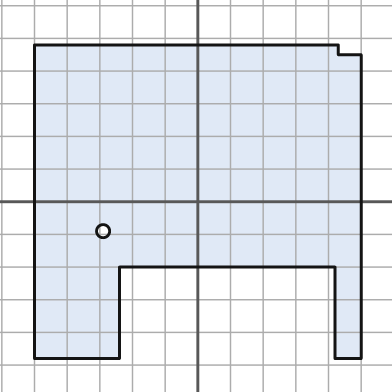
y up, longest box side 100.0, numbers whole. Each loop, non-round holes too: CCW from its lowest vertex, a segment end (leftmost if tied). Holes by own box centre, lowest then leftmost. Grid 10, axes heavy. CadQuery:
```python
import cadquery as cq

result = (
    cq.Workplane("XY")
    .moveTo(-50.0, -48.0)
    .lineTo(-24.0, -48.0)
    .lineTo(-24.0, -20.0)
    .lineTo(42.0, -20.0)
    .lineTo(42.0, -48.0)
    .lineTo(50.0, -48.0)
    .lineTo(50.0, 45.0)
    .lineTo(43.0, 45.0)
    .lineTo(43.0, 48.0)
    .lineTo(-50.0, 48.0)
    .close()
    .moveTo(-29.0, -9.0)
    .circle(2.0)
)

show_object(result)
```